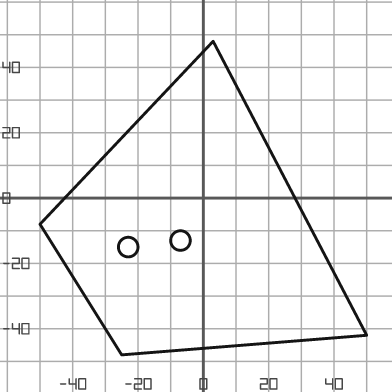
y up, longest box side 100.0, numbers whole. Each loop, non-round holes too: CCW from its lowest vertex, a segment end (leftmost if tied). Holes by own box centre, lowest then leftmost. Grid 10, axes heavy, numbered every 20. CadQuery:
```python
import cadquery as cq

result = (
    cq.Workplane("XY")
    .moveTo(-25.0, -48.0)
    .lineTo(50.0, -42.0)
    .lineTo(3.0, 48.0)
    .lineTo(-50.0, -8.0)
    .close()
    .moveTo(-23.0, -15.0)
    .circle(3.0)
    .moveTo(-7.0, -13.0)
    .circle(3.0)
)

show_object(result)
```